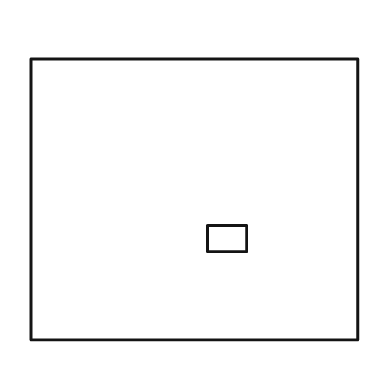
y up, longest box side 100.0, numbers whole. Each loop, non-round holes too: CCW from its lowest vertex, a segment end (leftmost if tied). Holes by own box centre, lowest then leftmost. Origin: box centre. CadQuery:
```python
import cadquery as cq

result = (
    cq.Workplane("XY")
    .moveTo(-50.0, -43.0)
    .lineTo(50.0, -43.0)
    .lineTo(50.0, 43.0)
    .lineTo(-50.0, 43.0)
    .close()
    .moveTo(4.0, -16.0)
    .lineTo(16.0, -16.0)
    .lineTo(16.0, -8.0)
    .lineTo(4.0, -8.0)
    .close()
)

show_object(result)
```